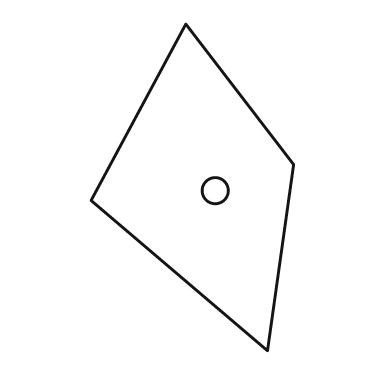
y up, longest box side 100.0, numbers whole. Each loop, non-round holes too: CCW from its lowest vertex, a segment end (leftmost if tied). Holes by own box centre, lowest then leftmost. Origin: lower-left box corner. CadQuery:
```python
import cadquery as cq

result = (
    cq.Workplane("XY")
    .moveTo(54.0, 0.0)
    .lineTo(62.0, 57.0)
    .lineTo(29.0, 100.0)
    .lineTo(0.0, 46.0)
    .close()
    .moveTo(38.0, 49.0)
    .circle(4.0)
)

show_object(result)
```